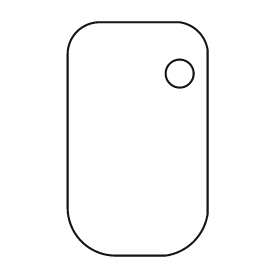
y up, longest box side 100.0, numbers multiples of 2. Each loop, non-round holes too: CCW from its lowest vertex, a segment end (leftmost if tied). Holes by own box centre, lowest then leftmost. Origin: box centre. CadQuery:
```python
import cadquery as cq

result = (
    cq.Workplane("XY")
    .moveTo(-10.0, -50.0)
    .lineTo(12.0, -50.0)
    .threePointArc((24.0, -44.0), (30.0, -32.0))
    .lineTo(30.0, 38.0)
    .threePointArc((26.0, 46.0), (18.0, 50.0))
    .lineTo(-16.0, 50.0)
    .threePointArc((-26.0, 46.0), (-30.0, 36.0))
    .lineTo(-30.0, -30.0)
    .threePointArc((-24.0, -44.0), (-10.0, -50.0))
    .close()
    .moveTo(18.0, 28.0)
    .circle(6.0)
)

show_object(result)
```